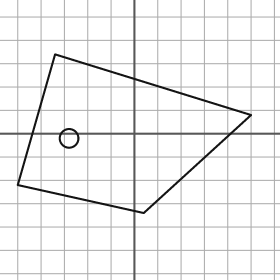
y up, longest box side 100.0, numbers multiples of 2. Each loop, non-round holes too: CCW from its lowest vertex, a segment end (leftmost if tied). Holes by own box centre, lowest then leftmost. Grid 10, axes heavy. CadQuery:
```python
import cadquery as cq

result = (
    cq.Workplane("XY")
    .moveTo(4.0, -34.0)
    .lineTo(50.0, 8.0)
    .lineTo(-34.0, 34.0)
    .lineTo(-50.0, -22.0)
    .close()
    .moveTo(-28.0, -2.0)
    .circle(4.0)
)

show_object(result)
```